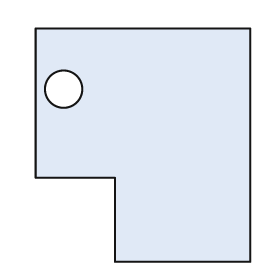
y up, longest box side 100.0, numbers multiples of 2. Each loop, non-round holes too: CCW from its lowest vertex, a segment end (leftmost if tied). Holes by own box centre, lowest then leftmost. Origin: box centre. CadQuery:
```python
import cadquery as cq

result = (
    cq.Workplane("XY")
    .moveTo(-12.0, -50.0)
    .lineTo(46.0, -50.0)
    .lineTo(46.0, 50.0)
    .lineTo(-46.0, 50.0)
    .lineTo(-46.0, -14.0)
    .lineTo(-12.0, -14.0)
    .close()
    .moveTo(-34.0, 24.0)
    .circle(8.0)
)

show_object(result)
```